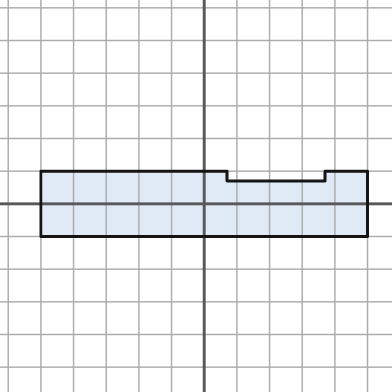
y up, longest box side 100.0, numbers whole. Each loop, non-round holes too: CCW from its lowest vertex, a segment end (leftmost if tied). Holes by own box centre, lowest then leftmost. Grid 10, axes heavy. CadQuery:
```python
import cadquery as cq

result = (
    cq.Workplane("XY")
    .moveTo(-50.0, -10.0)
    .lineTo(50.0, -10.0)
    .lineTo(50.0, 10.0)
    .lineTo(37.0, 10.0)
    .lineTo(37.0, 7.0)
    .lineTo(7.0, 7.0)
    .lineTo(7.0, 10.0)
    .lineTo(-50.0, 10.0)
    .close()
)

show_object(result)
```